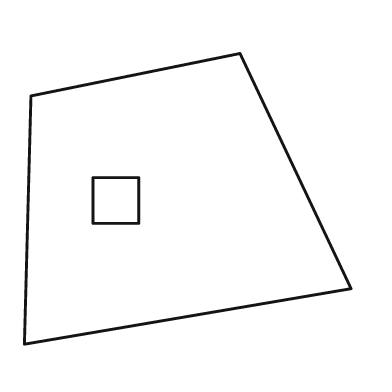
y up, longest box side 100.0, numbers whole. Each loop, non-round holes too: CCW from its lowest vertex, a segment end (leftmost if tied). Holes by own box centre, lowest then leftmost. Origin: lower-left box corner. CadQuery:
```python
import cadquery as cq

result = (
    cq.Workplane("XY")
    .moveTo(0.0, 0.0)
    .lineTo(100.0, 17.0)
    .lineTo(66.0, 89.0)
    .lineTo(2.0, 76.0)
    .close()
    .moveTo(21.0, 37.0)
    .lineTo(35.0, 37.0)
    .lineTo(35.0, 51.0)
    .lineTo(21.0, 51.0)
    .close()
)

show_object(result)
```